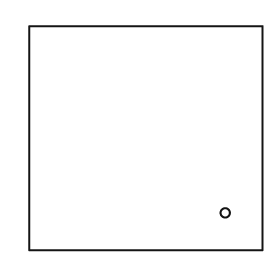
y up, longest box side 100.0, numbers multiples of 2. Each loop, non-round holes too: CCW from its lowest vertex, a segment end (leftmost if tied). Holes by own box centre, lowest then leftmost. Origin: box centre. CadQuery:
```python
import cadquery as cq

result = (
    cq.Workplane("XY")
    .moveTo(-50.0, -48.0)
    .lineTo(50.0, -48.0)
    .lineTo(50.0, 48.0)
    .lineTo(-50.0, 48.0)
    .close()
    .moveTo(34.0, -32.0)
    .circle(2.0)
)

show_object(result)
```